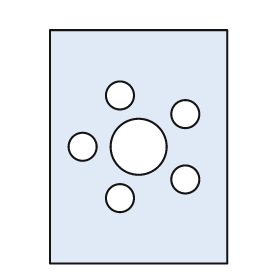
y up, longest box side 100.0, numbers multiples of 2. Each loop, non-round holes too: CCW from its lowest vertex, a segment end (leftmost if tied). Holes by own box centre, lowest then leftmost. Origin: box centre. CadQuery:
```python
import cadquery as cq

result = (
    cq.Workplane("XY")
    .moveTo(-38.0, -50.0)
    .lineTo(38.0, -50.0)
    .lineTo(38.0, 50.0)
    .lineTo(-38.0, 50.0)
    .close()
    .moveTo(-8.0, -22.0)
    .circle(6.0)
    .moveTo(20.0, -14.0)
    .circle(6.0)
    .moveTo(-24.0, 0.0)
    .circle(6.0)
    .moveTo(0.0, 0.0)
    .circle(12.0)
    .moveTo(20.0, 14.0)
    .circle(6.0)
    .moveTo(-8.0, 22.0)
    .circle(6.0)
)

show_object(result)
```